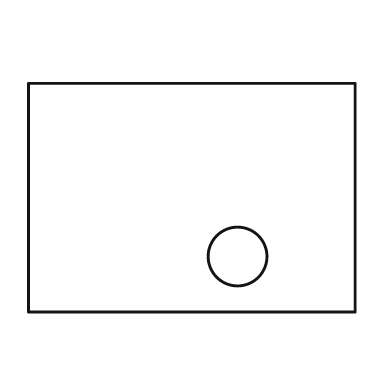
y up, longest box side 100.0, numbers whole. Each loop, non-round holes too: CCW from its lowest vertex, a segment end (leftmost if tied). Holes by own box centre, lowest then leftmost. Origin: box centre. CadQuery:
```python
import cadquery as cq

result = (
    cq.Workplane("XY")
    .moveTo(-50.0, -35.0)
    .lineTo(50.0, -35.0)
    .lineTo(50.0, 35.0)
    .lineTo(-50.0, 35.0)
    .close()
    .moveTo(14.0, -18.0)
    .circle(9.0)
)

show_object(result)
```